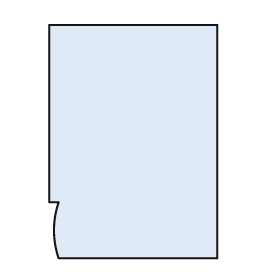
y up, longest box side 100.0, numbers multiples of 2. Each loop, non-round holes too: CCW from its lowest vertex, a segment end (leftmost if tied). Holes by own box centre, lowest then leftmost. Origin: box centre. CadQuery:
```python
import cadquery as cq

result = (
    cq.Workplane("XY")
    .moveTo(-32.0, -50.0)
    .lineTo(36.0, -50.0)
    .lineTo(36.0, 50.0)
    .lineTo(-36.0, 50.0)
    .lineTo(-36.0, -26.0)
    .lineTo(-32.0, -26.0)
    .threePointArc((-34.0, -38.0), (-32.0, -50.0))
    .close()
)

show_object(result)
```